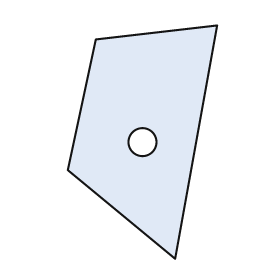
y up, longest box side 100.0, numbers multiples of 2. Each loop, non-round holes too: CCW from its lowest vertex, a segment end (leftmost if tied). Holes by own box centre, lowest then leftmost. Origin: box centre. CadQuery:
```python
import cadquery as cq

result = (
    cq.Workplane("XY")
    .moveTo(14.0, -50.0)
    .lineTo(32.0, 50.0)
    .lineTo(-20.0, 44.0)
    .lineTo(-32.0, -12.0)
    .close()
    .moveTo(0.0, 0.0)
    .circle(6.0)
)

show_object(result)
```